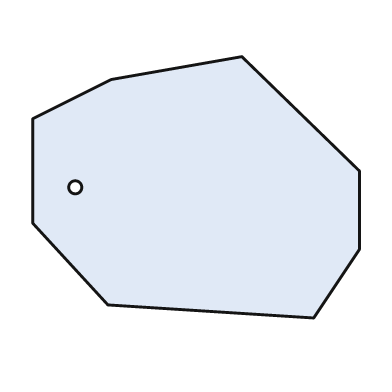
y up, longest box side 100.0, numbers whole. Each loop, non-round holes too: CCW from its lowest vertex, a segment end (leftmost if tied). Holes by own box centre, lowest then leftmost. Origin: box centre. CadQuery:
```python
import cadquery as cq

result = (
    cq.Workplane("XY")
    .moveTo(36.0, -40.0)
    .lineTo(50.0, -19.0)
    .lineTo(50.0, 5.0)
    .lineTo(14.0, 40.0)
    .lineTo(-26.0, 33.0)
    .lineTo(-50.0, 21.0)
    .lineTo(-50.0, -11.0)
    .lineTo(-27.0, -36.0)
    .close()
    .moveTo(-37.0, 0.0)
    .circle(2.0)
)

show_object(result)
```